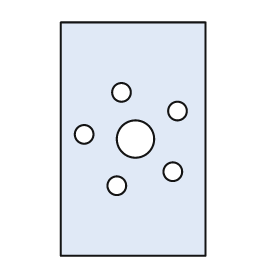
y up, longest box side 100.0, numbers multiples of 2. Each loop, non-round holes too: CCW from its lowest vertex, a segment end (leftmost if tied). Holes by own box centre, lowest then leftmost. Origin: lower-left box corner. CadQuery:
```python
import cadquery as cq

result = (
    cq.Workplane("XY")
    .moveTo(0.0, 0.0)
    .lineTo(62.0, 0.0)
    .lineTo(62.0, 100.0)
    .lineTo(0.0, 100.0)
    .close()
    .moveTo(24.0, 30.0)
    .circle(4.0)
    .moveTo(48.0, 36.0)
    .circle(4.0)
    .moveTo(32.0, 50.0)
    .circle(8.0)
    .moveTo(10.0, 52.0)
    .circle(4.0)
    .moveTo(50.0, 62.0)
    .circle(4.0)
    .moveTo(26.0, 70.0)
    .circle(4.0)
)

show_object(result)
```